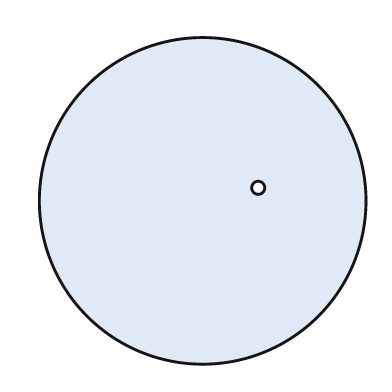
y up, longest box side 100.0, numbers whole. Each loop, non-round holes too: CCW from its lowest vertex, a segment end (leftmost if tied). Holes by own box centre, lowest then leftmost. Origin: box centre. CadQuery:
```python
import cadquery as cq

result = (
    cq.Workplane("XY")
    .moveTo(0.0, 0.0)
    .circle(50.0)
    .moveTo(17.0, 4.0)
    .circle(2.0)
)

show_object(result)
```